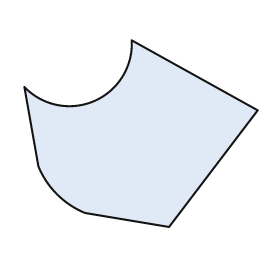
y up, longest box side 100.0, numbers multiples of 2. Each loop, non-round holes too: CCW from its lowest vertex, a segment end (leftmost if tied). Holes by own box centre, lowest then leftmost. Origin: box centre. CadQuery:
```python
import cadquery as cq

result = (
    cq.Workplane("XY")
    .moveTo(12.0, -40.0)
    .lineTo(50.0, 10.0)
    .lineTo(-4.0, 40.0)
    .threePointArc((-20.0, 14.0), (-50.0, 20.0))
    .lineTo(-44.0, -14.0)
    .threePointArc((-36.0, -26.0), (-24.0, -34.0))
    .close()
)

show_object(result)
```